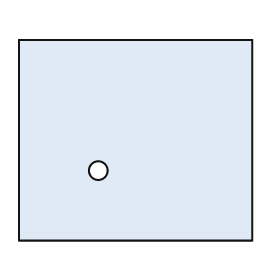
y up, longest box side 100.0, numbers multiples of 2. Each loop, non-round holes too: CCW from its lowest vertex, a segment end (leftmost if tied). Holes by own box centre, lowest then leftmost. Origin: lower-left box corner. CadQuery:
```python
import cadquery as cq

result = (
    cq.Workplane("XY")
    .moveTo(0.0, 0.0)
    .lineTo(100.0, 0.0)
    .lineTo(100.0, 86.0)
    .lineTo(0.0, 86.0)
    .close()
    .moveTo(34.0, 30.0)
    .circle(4.0)
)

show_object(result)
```